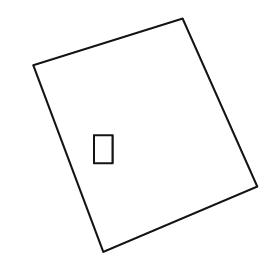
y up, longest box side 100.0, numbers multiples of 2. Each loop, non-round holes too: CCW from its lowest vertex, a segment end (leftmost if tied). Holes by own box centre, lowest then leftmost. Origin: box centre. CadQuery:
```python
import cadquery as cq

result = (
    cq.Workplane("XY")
    .moveTo(-18.0, -50.0)
    .lineTo(48.0, -22.0)
    .lineTo(16.0, 50.0)
    .lineTo(-48.0, 30.0)
    .close()
    .moveTo(-22.0, -12.0)
    .lineTo(-14.0, -12.0)
    .lineTo(-14.0, 0.0)
    .lineTo(-22.0, 0.0)
    .close()
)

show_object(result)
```